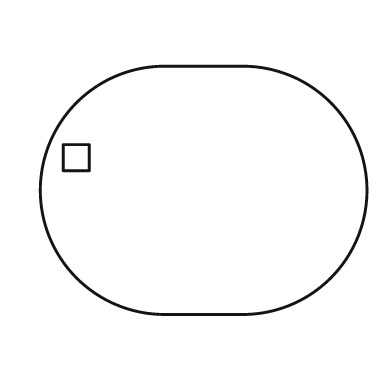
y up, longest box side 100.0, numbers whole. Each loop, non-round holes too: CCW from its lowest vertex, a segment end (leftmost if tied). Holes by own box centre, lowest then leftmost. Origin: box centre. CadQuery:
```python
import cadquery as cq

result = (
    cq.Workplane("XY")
    .moveTo(-12.0, -38.0)
    .lineTo(12.0, -38.0)
    .threePointArc((50.0, 0.0), (12.0, 38.0))
    .lineTo(-12.0, 38.0)
    .threePointArc((-50.0, 0.0), (-12.0, -38.0))
    .close()
    .moveTo(-43.0, 6.0)
    .lineTo(-35.0, 6.0)
    .lineTo(-35.0, 14.0)
    .lineTo(-43.0, 14.0)
    .close()
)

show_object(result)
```